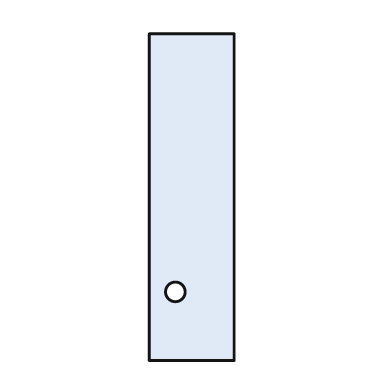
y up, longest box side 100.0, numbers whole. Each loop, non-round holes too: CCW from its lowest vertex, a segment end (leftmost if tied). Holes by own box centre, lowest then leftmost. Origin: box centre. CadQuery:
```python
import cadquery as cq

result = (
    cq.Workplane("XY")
    .moveTo(-13.0, -50.0)
    .lineTo(13.0, -50.0)
    .lineTo(13.0, 50.0)
    .lineTo(-13.0, 50.0)
    .close()
    .moveTo(-5.0, -29.0)
    .circle(3.0)
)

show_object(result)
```